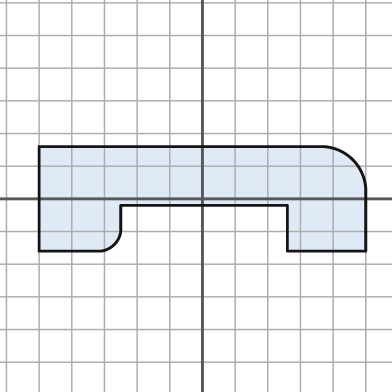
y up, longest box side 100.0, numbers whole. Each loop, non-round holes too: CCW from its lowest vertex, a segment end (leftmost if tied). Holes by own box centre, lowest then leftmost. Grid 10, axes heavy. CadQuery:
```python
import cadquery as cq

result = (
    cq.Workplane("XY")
    .moveTo(-50.0, -16.0)
    .lineTo(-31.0, -16.0)
    .threePointArc((-27.0, -14.0), (-25.0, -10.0))
    .lineTo(-25.0, -2.0)
    .lineTo(26.0, -2.0)
    .lineTo(26.0, -16.0)
    .lineTo(50.0, -16.0)
    .lineTo(50.0, 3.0)
    .threePointArc((46.0, 12.0), (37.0, 16.0))
    .lineTo(-50.0, 16.0)
    .close()
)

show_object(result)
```